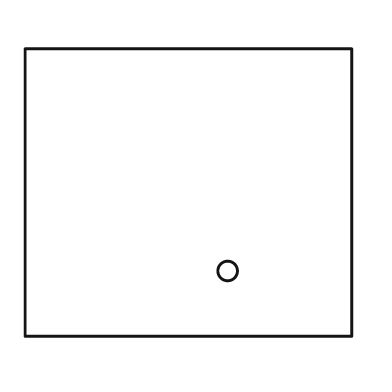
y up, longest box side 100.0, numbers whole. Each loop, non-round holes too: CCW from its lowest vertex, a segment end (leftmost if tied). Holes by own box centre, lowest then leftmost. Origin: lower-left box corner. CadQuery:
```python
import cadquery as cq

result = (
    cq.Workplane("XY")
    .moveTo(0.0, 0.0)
    .lineTo(100.0, 0.0)
    .lineTo(100.0, 88.0)
    .lineTo(0.0, 88.0)
    .close()
    .moveTo(62.0, 20.0)
    .circle(3.0)
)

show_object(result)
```